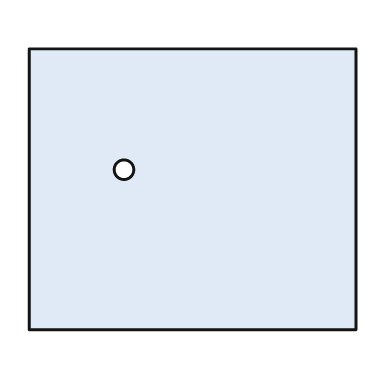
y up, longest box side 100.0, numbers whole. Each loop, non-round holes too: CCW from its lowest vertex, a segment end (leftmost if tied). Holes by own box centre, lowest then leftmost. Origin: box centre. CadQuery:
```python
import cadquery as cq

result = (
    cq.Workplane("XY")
    .moveTo(-50.0, -43.0)
    .lineTo(50.0, -43.0)
    .lineTo(50.0, 43.0)
    .lineTo(-50.0, 43.0)
    .close()
    .moveTo(-21.0, 6.0)
    .circle(3.0)
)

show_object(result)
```